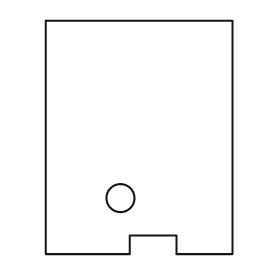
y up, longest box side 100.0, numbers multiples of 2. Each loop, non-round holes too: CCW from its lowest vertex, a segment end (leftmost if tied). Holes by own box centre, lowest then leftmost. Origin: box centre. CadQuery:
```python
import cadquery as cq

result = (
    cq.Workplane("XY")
    .moveTo(-40.0, -50.0)
    .lineTo(-4.0, -50.0)
    .lineTo(-4.0, -42.0)
    .lineTo(16.0, -42.0)
    .lineTo(16.0, -50.0)
    .lineTo(40.0, -50.0)
    .lineTo(40.0, 50.0)
    .lineTo(-40.0, 50.0)
    .close()
    .moveTo(-8.0, -26.0)
    .circle(6.0)
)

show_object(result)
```